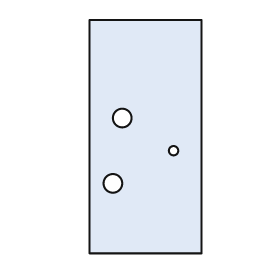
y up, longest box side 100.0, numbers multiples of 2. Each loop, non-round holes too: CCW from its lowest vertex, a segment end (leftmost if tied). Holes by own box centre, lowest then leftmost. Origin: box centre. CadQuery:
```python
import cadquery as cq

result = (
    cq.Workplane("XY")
    .moveTo(-24.0, -50.0)
    .lineTo(24.0, -50.0)
    .lineTo(24.0, 50.0)
    .lineTo(-24.0, 50.0)
    .close()
    .moveTo(-14.0, -20.0)
    .circle(4.0)
    .moveTo(12.0, -6.0)
    .circle(2.0)
    .moveTo(-10.0, 8.0)
    .circle(4.0)
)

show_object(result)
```